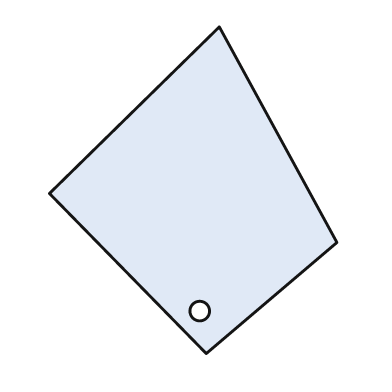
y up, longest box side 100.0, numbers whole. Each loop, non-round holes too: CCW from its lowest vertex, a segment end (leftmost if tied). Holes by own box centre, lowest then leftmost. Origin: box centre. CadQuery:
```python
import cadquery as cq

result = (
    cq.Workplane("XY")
    .moveTo(4.0, -50.0)
    .lineTo(44.0, -16.0)
    .lineTo(8.0, 50.0)
    .lineTo(-44.0, -1.0)
    .close()
    .moveTo(2.0, -37.0)
    .circle(3.0)
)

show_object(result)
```